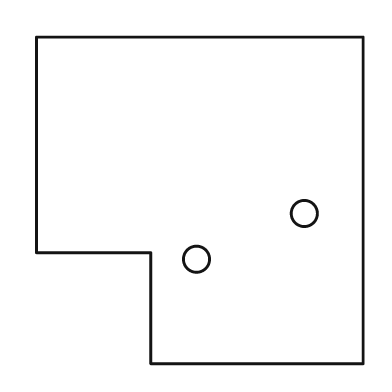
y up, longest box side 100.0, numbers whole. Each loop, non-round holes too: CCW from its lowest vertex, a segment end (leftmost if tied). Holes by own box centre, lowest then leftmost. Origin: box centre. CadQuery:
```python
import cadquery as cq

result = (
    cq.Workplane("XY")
    .moveTo(-15.0, -50.0)
    .lineTo(50.0, -50.0)
    .lineTo(50.0, 50.0)
    .lineTo(-50.0, 50.0)
    .lineTo(-50.0, -16.0)
    .lineTo(-15.0, -16.0)
    .close()
    .moveTo(-1.0, -18.0)
    .circle(4.0)
    .moveTo(32.0, -4.0)
    .circle(4.0)
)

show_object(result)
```